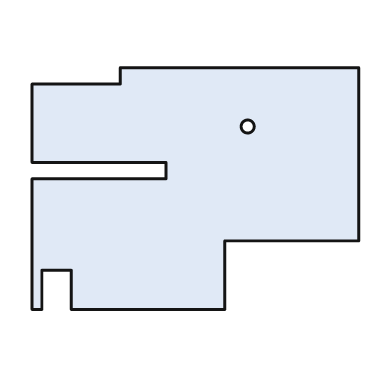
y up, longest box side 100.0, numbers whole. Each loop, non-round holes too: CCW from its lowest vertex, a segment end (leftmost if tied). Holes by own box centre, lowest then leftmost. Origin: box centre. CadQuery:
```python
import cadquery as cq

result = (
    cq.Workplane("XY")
    .moveTo(-50.0, -37.0)
    .lineTo(-47.0, -37.0)
    .lineTo(-47.0, -25.0)
    .lineTo(-38.0, -25.0)
    .lineTo(-38.0, -37.0)
    .lineTo(9.0, -37.0)
    .lineTo(9.0, -16.0)
    .lineTo(50.0, -16.0)
    .lineTo(50.0, 37.0)
    .lineTo(-23.0, 37.0)
    .lineTo(-23.0, 32.0)
    .lineTo(-50.0, 32.0)
    .lineTo(-50.0, 8.0)
    .lineTo(-9.0, 8.0)
    .lineTo(-9.0, 3.0)
    .lineTo(-50.0, 3.0)
    .close()
    .moveTo(16.0, 19.0)
    .circle(2.0)
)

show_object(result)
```